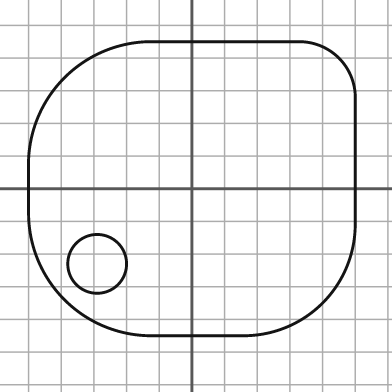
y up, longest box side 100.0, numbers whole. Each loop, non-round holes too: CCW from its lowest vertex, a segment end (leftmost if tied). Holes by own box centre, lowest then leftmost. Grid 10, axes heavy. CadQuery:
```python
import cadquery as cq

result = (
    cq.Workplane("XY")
    .moveTo(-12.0, -45.0)
    .lineTo(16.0, -45.0)
    .threePointArc((40.0, -35.0), (50.0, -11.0))
    .lineTo(50.0, 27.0)
    .threePointArc((45.0, 40.0), (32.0, 45.0))
    .lineTo(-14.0, 45.0)
    .threePointArc((-39.0, 34.0), (-50.0, 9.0))
    .lineTo(-50.0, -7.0)
    .threePointArc((-39.0, -34.0), (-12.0, -45.0))
    .close()
    .moveTo(-29.0, -23.0)
    .circle(9.0)
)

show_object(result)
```